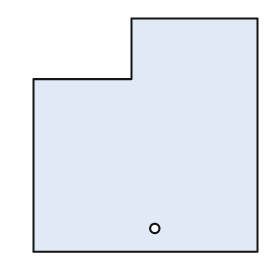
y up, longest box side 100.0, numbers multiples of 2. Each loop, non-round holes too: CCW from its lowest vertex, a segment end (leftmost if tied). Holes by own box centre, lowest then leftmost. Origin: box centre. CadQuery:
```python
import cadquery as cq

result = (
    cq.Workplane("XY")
    .moveTo(-48.0, -50.0)
    .lineTo(48.0, -50.0)
    .lineTo(48.0, 50.0)
    .lineTo(-6.0, 50.0)
    .lineTo(-6.0, 24.0)
    .lineTo(-48.0, 24.0)
    .close()
    .moveTo(4.0, -40.0)
    .circle(2.0)
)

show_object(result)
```